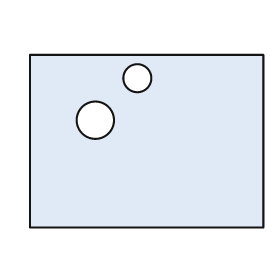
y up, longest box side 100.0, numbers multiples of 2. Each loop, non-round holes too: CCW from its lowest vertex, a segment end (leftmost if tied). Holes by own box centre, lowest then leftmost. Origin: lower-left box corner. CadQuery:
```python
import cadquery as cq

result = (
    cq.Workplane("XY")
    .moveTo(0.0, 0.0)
    .lineTo(100.0, 0.0)
    .lineTo(100.0, 74.0)
    .lineTo(0.0, 74.0)
    .close()
    .moveTo(28.0, 46.0)
    .circle(8.0)
    .moveTo(46.0, 64.0)
    .circle(6.0)
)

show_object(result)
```